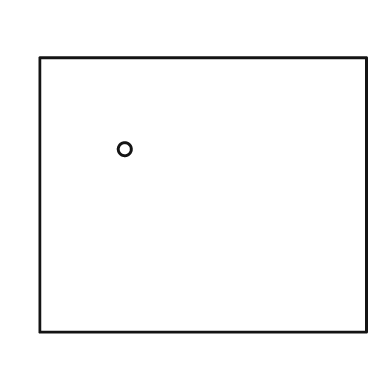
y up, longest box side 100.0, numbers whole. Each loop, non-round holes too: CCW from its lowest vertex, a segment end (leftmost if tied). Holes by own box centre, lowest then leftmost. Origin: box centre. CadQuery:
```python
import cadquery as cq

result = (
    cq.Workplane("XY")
    .moveTo(-50.0, -42.0)
    .lineTo(50.0, -42.0)
    .lineTo(50.0, 42.0)
    .lineTo(-50.0, 42.0)
    .close()
    .moveTo(-24.0, 14.0)
    .circle(2.0)
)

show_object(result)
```